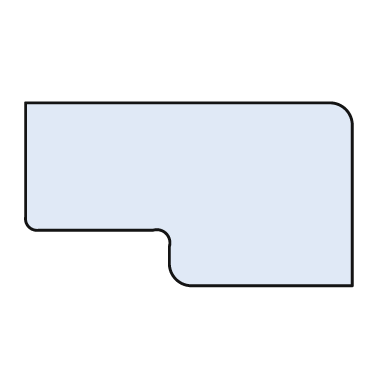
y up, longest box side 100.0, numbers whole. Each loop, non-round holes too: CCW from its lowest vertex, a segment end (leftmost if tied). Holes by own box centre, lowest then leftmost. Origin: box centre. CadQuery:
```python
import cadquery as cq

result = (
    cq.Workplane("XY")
    .moveTo(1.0, -28.0)
    .lineTo(50.0, -28.0)
    .lineTo(50.0, 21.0)
    .threePointArc((48.0, 26.0), (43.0, 28.0))
    .lineTo(-50.0, 28.0)
    .lineTo(-50.0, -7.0)
    .threePointArc((-49.0, -10.0), (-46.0, -11.0))
    .lineTo(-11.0, -11.0)
    .threePointArc((-7.0, -12.0), (-6.0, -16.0))
    .lineTo(-6.0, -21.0)
    .threePointArc((-4.0, -26.0), (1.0, -28.0))
    .close()
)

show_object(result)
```